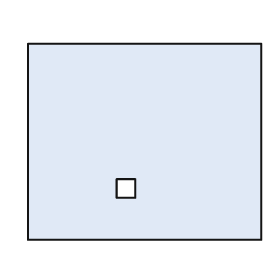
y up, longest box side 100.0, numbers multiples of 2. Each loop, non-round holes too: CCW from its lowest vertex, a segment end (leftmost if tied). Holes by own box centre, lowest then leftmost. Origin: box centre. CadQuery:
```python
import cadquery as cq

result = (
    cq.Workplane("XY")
    .moveTo(-50.0, -42.0)
    .lineTo(50.0, -42.0)
    .lineTo(50.0, 42.0)
    .lineTo(-50.0, 42.0)
    .close()
    .moveTo(-12.0, -24.0)
    .lineTo(-4.0, -24.0)
    .lineTo(-4.0, -16.0)
    .lineTo(-12.0, -16.0)
    .close()
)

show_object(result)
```